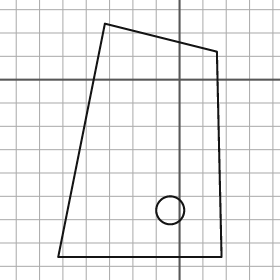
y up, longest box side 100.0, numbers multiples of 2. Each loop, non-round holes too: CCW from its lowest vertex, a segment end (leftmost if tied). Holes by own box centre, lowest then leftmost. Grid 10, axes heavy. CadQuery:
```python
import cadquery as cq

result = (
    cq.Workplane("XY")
    .moveTo(-52.0, -76.0)
    .lineTo(18.0, -76.0)
    .lineTo(16.0, 12.0)
    .lineTo(-32.0, 24.0)
    .close()
    .moveTo(-4.0, -56.0)
    .circle(6.0)
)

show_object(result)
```